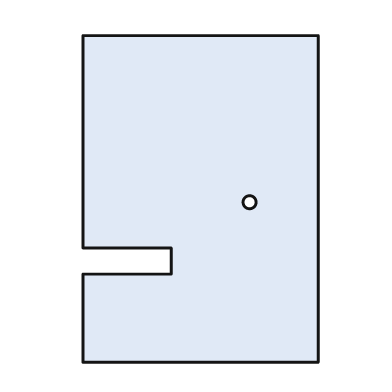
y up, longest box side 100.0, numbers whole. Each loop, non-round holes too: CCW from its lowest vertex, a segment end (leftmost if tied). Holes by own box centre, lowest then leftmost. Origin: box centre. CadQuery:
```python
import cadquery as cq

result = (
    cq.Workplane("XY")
    .moveTo(-36.0, -50.0)
    .lineTo(36.0, -50.0)
    .lineTo(36.0, 50.0)
    .lineTo(-36.0, 50.0)
    .lineTo(-36.0, -15.0)
    .lineTo(-9.0, -15.0)
    .lineTo(-9.0, -23.0)
    .lineTo(-36.0, -23.0)
    .close()
    .moveTo(15.0, -1.0)
    .circle(2.0)
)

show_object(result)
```